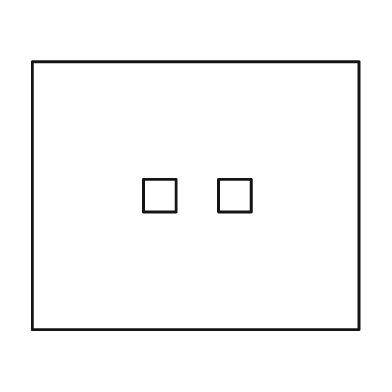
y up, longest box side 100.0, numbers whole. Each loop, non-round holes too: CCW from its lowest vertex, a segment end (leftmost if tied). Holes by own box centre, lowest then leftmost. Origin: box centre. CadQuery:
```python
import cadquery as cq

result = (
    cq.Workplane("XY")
    .moveTo(-50.0, -41.0)
    .lineTo(50.0, -41.0)
    .lineTo(50.0, 41.0)
    .lineTo(-50.0, 41.0)
    .close()
    .moveTo(-16.0, -5.0)
    .lineTo(-6.0, -5.0)
    .lineTo(-6.0, 5.0)
    .lineTo(-16.0, 5.0)
    .close()
    .moveTo(7.0, -5.0)
    .lineTo(17.0, -5.0)
    .lineTo(17.0, 5.0)
    .lineTo(7.0, 5.0)
    .close()
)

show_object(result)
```